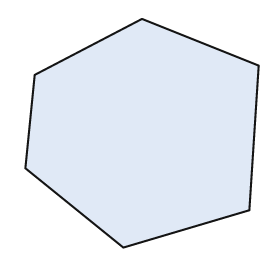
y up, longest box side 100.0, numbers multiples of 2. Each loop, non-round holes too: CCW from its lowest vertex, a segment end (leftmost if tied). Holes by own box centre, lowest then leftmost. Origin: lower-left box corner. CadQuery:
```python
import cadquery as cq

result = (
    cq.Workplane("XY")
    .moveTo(42.0, 0.0)
    .lineTo(96.0, 16.0)
    .lineTo(100.0, 78.0)
    .lineTo(50.0, 98.0)
    .lineTo(4.0, 74.0)
    .lineTo(0.0, 34.0)
    .close()
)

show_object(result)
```